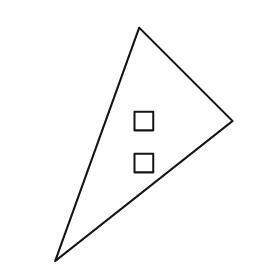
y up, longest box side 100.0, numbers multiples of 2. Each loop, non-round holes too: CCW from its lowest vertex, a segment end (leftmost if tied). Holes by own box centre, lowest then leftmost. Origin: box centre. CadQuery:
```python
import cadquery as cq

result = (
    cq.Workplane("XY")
    .moveTo(-38.0, -50.0)
    .lineTo(38.0, 10.0)
    .lineTo(-2.0, 50.0)
    .close()
    .moveTo(-4.0, -12.0)
    .lineTo(4.0, -12.0)
    .lineTo(4.0, -4.0)
    .lineTo(-4.0, -4.0)
    .close()
    .moveTo(-4.0, 6.0)
    .lineTo(4.0, 6.0)
    .lineTo(4.0, 14.0)
    .lineTo(-4.0, 14.0)
    .close()
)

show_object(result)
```